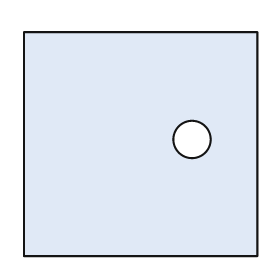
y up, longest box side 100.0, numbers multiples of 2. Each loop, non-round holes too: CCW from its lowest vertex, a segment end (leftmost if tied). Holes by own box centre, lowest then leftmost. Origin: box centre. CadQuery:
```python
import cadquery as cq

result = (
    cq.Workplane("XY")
    .moveTo(-50.0, -48.0)
    .lineTo(50.0, -48.0)
    .lineTo(50.0, 48.0)
    .lineTo(-50.0, 48.0)
    .close()
    .moveTo(22.0, 2.0)
    .circle(8.0)
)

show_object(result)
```